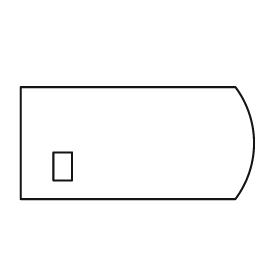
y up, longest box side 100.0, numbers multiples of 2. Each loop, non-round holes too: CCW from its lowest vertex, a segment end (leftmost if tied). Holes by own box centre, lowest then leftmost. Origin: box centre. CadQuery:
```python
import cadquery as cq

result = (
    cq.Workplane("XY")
    .moveTo(-50.0, -24.0)
    .lineTo(42.0, -24.0)
    .threePointArc((50.0, 0.0), (42.0, 24.0))
    .lineTo(-50.0, 24.0)
    .close()
    .moveTo(-36.0, -16.0)
    .lineTo(-28.0, -16.0)
    .lineTo(-28.0, -4.0)
    .lineTo(-36.0, -4.0)
    .close()
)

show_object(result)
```